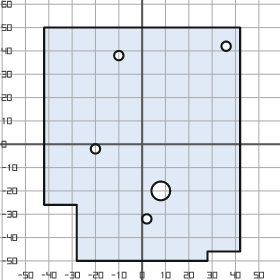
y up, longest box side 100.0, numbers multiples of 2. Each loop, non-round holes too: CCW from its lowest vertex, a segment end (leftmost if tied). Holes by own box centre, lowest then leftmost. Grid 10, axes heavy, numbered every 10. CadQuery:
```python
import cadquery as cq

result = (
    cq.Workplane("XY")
    .moveTo(-28.0, -50.0)
    .lineTo(28.0, -50.0)
    .lineTo(28.0, -46.0)
    .lineTo(42.0, -46.0)
    .lineTo(42.0, 50.0)
    .lineTo(-42.0, 50.0)
    .lineTo(-42.0, -26.0)
    .lineTo(-28.0, -26.0)
    .close()
    .moveTo(2.0, -32.0)
    .circle(2.0)
    .moveTo(8.0, -20.0)
    .circle(4.0)
    .moveTo(-20.0, -2.0)
    .circle(2.0)
    .moveTo(-10.0, 38.0)
    .circle(2.0)
    .moveTo(36.0, 42.0)
    .circle(2.0)
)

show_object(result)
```